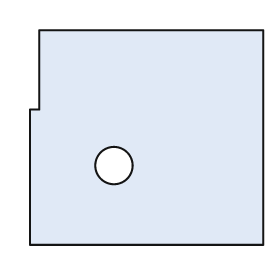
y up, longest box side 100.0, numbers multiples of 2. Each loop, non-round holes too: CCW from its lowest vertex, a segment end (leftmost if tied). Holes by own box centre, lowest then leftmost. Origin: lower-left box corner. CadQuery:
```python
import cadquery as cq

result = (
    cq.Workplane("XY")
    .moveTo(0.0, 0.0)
    .lineTo(100.0, 0.0)
    .lineTo(100.0, 92.0)
    .lineTo(4.0, 92.0)
    .lineTo(4.0, 58.0)
    .lineTo(0.0, 58.0)
    .close()
    .moveTo(36.0, 34.0)
    .circle(8.0)
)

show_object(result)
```